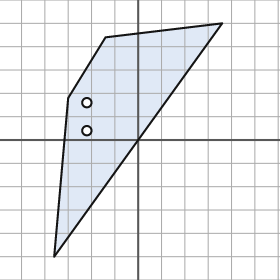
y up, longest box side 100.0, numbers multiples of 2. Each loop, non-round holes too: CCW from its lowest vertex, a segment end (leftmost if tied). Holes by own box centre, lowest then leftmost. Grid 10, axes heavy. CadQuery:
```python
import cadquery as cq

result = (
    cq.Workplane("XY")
    .moveTo(-36.0, -50.0)
    .lineTo(36.0, 50.0)
    .lineTo(-14.0, 44.0)
    .lineTo(-30.0, 18.0)
    .close()
    .moveTo(-22.0, 4.0)
    .circle(2.0)
    .moveTo(-22.0, 16.0)
    .circle(2.0)
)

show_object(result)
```